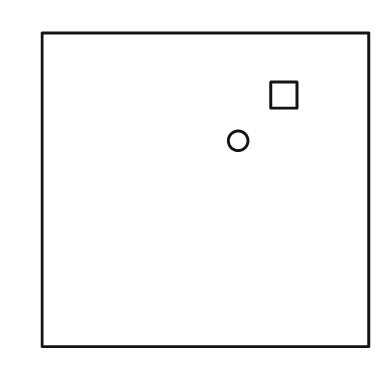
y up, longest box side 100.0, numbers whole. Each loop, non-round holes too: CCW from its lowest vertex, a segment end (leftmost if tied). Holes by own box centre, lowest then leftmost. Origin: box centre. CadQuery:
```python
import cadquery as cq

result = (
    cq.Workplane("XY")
    .moveTo(-50.0, -48.0)
    .lineTo(50.0, -48.0)
    .lineTo(50.0, 48.0)
    .lineTo(-50.0, 48.0)
    .close()
    .moveTo(10.0, 15.0)
    .circle(3.0)
    .moveTo(20.0, 25.0)
    .lineTo(28.0, 25.0)
    .lineTo(28.0, 33.0)
    .lineTo(20.0, 33.0)
    .close()
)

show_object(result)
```